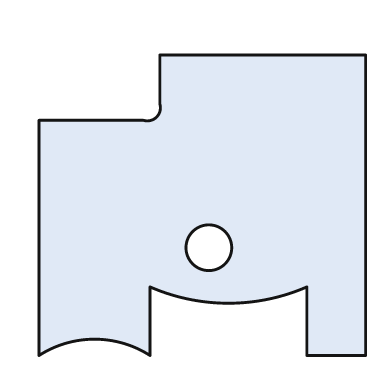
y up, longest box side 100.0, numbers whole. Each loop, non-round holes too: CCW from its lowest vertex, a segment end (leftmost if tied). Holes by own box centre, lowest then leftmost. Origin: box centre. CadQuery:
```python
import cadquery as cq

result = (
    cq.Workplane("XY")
    .moveTo(-50.0, -46.0)
    .threePointArc((-33.0, -41.0), (-16.0, -46.0))
    .lineTo(-16.0, -25.0)
    .threePointArc((8.0, -30.0), (32.0, -25.0))
    .lineTo(32.0, -46.0)
    .lineTo(50.0, -46.0)
    .lineTo(50.0, 46.0)
    .lineTo(-13.0, 46.0)
    .lineTo(-13.0, 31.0)
    .threePointArc((-14.0, 27.0), (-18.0, 26.0))
    .lineTo(-50.0, 26.0)
    .close()
    .moveTo(2.0, -13.0)
    .circle(7.0)
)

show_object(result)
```